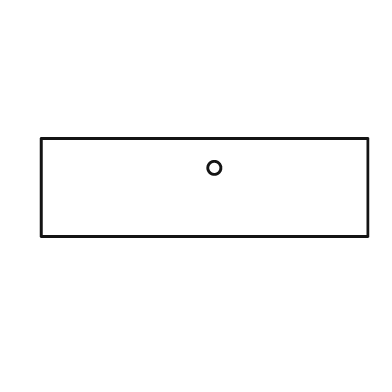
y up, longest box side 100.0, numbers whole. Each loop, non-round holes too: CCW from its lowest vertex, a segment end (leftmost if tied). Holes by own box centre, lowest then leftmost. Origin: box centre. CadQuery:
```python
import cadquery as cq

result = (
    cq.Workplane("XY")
    .moveTo(-50.0, -15.0)
    .lineTo(50.0, -15.0)
    .lineTo(50.0, 15.0)
    .lineTo(-50.0, 15.0)
    .close()
    .moveTo(3.0, 6.0)
    .circle(2.0)
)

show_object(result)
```